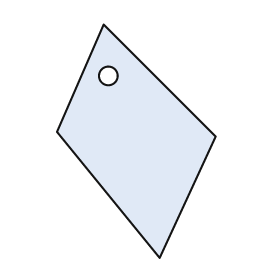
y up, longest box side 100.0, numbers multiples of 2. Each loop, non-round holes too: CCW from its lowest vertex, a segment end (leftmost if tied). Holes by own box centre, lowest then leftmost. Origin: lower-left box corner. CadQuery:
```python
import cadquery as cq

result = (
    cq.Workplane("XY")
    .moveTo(44.0, 0.0)
    .lineTo(68.0, 52.0)
    .lineTo(20.0, 100.0)
    .lineTo(0.0, 54.0)
    .close()
    .moveTo(22.0, 78.0)
    .circle(4.0)
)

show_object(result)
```